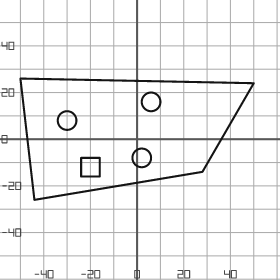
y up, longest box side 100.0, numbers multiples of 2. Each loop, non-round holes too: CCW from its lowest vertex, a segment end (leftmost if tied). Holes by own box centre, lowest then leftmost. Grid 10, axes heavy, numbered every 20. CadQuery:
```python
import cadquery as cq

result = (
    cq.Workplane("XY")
    .moveTo(-44.0, -26.0)
    .lineTo(28.0, -14.0)
    .lineTo(50.0, 24.0)
    .lineTo(-50.0, 26.0)
    .close()
    .moveTo(-24.0, -16.0)
    .lineTo(-16.0, -16.0)
    .lineTo(-16.0, -8.0)
    .lineTo(-24.0, -8.0)
    .close()
    .moveTo(2.0, -8.0)
    .circle(4.0)
    .moveTo(-30.0, 8.0)
    .circle(4.0)
    .moveTo(6.0, 16.0)
    .circle(4.0)
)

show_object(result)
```